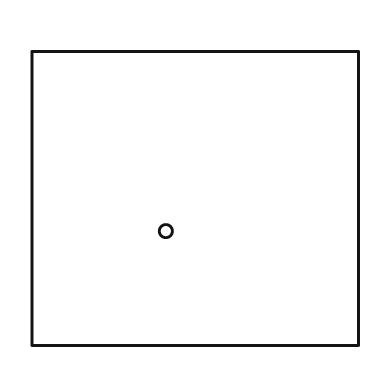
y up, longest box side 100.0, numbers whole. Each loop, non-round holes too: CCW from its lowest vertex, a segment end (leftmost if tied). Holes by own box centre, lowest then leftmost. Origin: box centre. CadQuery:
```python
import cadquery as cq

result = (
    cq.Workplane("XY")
    .moveTo(-50.0, -45.0)
    .lineTo(50.0, -45.0)
    .lineTo(50.0, 45.0)
    .lineTo(-50.0, 45.0)
    .close()
    .moveTo(-9.0, -10.0)
    .circle(2.0)
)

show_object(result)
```